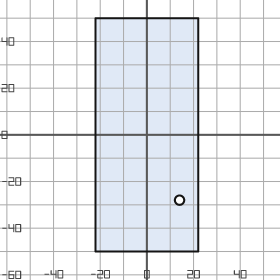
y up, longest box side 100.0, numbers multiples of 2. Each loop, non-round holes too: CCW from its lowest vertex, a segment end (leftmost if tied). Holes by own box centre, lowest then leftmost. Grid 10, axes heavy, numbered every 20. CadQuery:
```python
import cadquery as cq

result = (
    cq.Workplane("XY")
    .moveTo(-22.0, -50.0)
    .lineTo(22.0, -50.0)
    .lineTo(22.0, 50.0)
    .lineTo(-22.0, 50.0)
    .close()
    .moveTo(14.0, -28.0)
    .circle(2.0)
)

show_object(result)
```